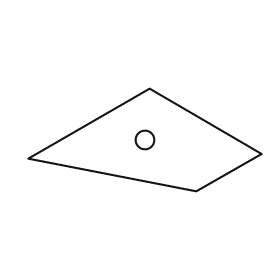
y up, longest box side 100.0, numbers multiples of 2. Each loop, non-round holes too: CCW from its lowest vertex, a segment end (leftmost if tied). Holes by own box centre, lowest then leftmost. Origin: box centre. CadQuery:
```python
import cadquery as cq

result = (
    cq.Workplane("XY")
    .moveTo(22.0, -22.0)
    .lineTo(50.0, -6.0)
    .lineTo(2.0, 22.0)
    .lineTo(-50.0, -8.0)
    .close()
    .moveTo(0.0, 0.0)
    .circle(4.0)
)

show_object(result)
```